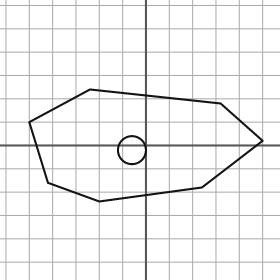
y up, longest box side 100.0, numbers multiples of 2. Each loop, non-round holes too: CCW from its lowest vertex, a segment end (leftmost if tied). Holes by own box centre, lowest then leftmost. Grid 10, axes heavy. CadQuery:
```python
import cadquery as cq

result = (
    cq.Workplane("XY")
    .moveTo(-20.0, -24.0)
    .lineTo(24.0, -18.0)
    .lineTo(50.0, 2.0)
    .lineTo(32.0, 18.0)
    .lineTo(-24.0, 24.0)
    .lineTo(-50.0, 10.0)
    .lineTo(-42.0, -16.0)
    .close()
    .moveTo(-6.0, -2.0)
    .circle(6.0)
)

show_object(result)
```